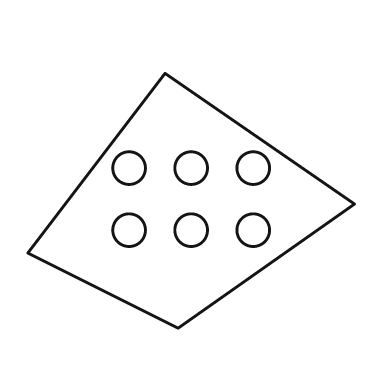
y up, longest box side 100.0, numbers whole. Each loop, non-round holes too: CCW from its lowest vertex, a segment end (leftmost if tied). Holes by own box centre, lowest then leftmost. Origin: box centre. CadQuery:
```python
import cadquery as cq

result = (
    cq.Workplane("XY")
    .moveTo(-4.0, -39.0)
    .lineTo(50.0, -1.0)
    .lineTo(-8.0, 39.0)
    .lineTo(-50.0, -16.0)
    .close()
    .moveTo(-19.0, -9.0)
    .circle(5.0)
    .moveTo(0.0, -9.0)
    .circle(5.0)
    .moveTo(19.0, -9.0)
    .circle(5.0)
    .moveTo(-19.0, 10.0)
    .circle(5.0)
    .moveTo(0.0, 10.0)
    .circle(5.0)
    .moveTo(19.0, 10.0)
    .circle(5.0)
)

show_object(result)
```